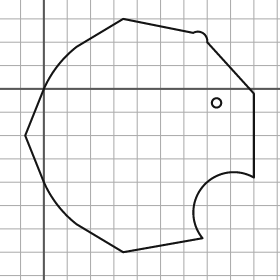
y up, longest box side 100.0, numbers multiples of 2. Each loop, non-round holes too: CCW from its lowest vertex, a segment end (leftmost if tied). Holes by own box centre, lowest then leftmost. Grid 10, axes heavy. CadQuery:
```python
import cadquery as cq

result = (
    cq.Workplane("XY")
    .moveTo(34.0, -70.0)
    .lineTo(68.0, -64.0)
    .threePointArc((68.0, -42.0), (90.0, -38.0))
    .lineTo(90.0, -2.0)
    .lineTo(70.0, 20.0)
    .threePointArc((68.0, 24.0), (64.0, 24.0))
    .lineTo(34.0, 30.0)
    .lineTo(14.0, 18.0)
    .threePointArc((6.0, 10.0), (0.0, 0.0))
    .lineTo(-8.0, -20.0)
    .lineTo(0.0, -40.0)
    .threePointArc((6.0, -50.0), (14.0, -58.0))
    .close()
    .moveTo(74.0, -6.0)
    .circle(2.0)
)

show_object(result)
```